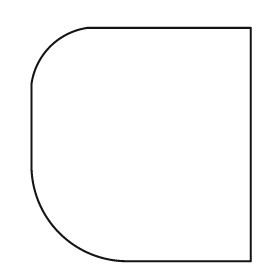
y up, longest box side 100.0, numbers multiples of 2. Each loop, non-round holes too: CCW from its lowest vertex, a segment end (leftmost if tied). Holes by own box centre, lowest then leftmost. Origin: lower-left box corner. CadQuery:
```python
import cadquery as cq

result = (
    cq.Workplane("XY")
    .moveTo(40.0, 0.0)
    .lineTo(94.0, 0.0)
    .lineTo(94.0, 100.0)
    .lineTo(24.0, 100.0)
    .threePointArc((8.0, 92.0), (0.0, 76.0))
    .lineTo(0.0, 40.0)
    .threePointArc((12.0, 12.0), (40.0, 0.0))
    .close()
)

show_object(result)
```